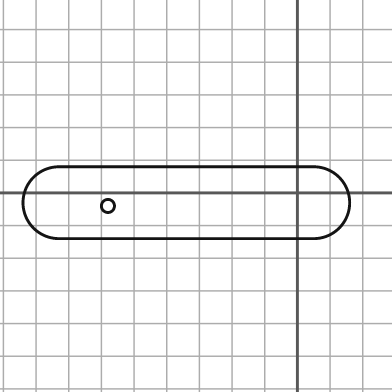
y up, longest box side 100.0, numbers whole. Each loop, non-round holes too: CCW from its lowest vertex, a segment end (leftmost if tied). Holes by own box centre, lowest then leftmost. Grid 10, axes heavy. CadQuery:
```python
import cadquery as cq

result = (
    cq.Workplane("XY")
    .moveTo(-73.0, -14.0)
    .lineTo(5.0, -14.0)
    .threePointArc((16.0, -3.0), (5.0, 8.0))
    .lineTo(-73.0, 8.0)
    .threePointArc((-84.0, -3.0), (-73.0, -14.0))
    .close()
    .moveTo(-58.0, -4.0)
    .circle(2.0)
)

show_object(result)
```